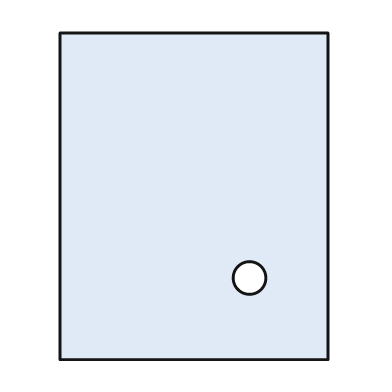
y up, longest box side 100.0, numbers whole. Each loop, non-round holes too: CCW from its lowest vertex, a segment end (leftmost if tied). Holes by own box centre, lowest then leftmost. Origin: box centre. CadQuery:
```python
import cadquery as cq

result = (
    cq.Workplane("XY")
    .moveTo(-41.0, -50.0)
    .lineTo(41.0, -50.0)
    .lineTo(41.0, 50.0)
    .lineTo(-41.0, 50.0)
    .close()
    .moveTo(17.0, -25.0)
    .circle(5.0)
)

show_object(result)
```